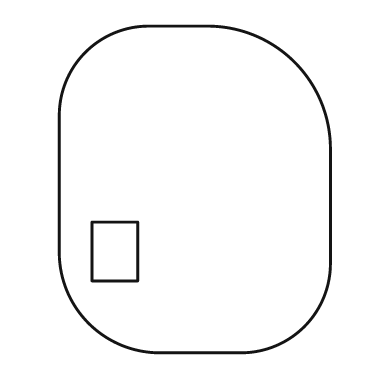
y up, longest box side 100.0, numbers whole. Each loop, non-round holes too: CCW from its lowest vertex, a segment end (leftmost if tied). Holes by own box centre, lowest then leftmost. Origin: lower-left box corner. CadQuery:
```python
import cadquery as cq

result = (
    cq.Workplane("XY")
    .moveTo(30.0, 0.0)
    .lineTo(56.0, 0.0)
    .threePointArc((75.0, 8.0), (83.0, 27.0))
    .lineTo(83.0, 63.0)
    .threePointArc((72.0, 89.0), (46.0, 100.0))
    .lineTo(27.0, 100.0)
    .threePointArc((8.0, 92.0), (0.0, 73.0))
    .lineTo(0.0, 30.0)
    .threePointArc((9.0, 9.0), (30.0, 0.0))
    .close()
    .moveTo(10.0, 22.0)
    .lineTo(24.0, 22.0)
    .lineTo(24.0, 40.0)
    .lineTo(10.0, 40.0)
    .close()
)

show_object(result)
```